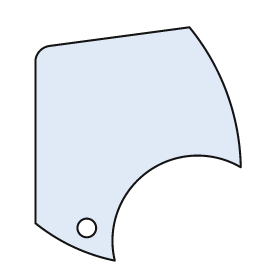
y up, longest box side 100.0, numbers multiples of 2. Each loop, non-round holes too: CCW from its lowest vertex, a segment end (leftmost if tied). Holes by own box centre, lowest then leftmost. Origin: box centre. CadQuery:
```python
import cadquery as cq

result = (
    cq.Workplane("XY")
    .moveTo(-10.0, -50.0)
    .threePointArc((4.0, -12.0), (44.0, -10.0))
    .threePointArc((38.0, 22.0), (22.0, 50.0))
    .lineTo(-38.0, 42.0)
    .threePointArc((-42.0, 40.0), (-44.0, 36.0))
    .lineTo(-44.0, -34.0)
    .threePointArc((-28.0, -44.0), (-10.0, -50.0))
    .close()
    .moveTo(-22.0, -36.0)
    .circle(4.0)
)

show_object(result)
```